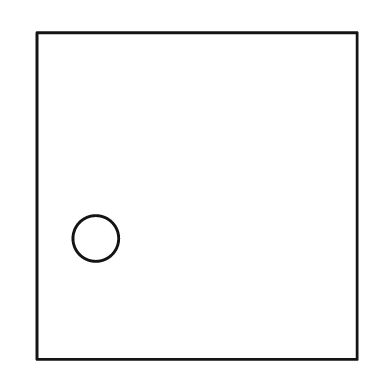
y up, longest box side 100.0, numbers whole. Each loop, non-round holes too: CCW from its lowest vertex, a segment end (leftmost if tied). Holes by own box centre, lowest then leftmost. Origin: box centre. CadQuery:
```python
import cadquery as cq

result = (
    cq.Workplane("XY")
    .moveTo(-49.0, -50.0)
    .lineTo(49.0, -50.0)
    .lineTo(49.0, 50.0)
    .lineTo(-49.0, 50.0)
    .close()
    .moveTo(-31.0, -13.0)
    .circle(7.0)
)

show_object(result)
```